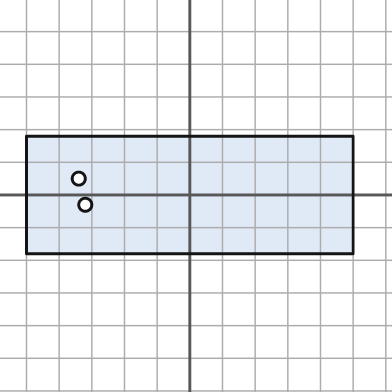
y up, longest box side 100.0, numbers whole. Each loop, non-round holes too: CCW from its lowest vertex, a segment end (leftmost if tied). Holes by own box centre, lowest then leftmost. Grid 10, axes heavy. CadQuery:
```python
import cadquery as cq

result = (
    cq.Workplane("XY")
    .moveTo(-50.0, -18.0)
    .lineTo(50.0, -18.0)
    .lineTo(50.0, 18.0)
    .lineTo(-50.0, 18.0)
    .close()
    .moveTo(-32.0, -3.0)
    .circle(2.0)
    .moveTo(-34.0, 5.0)
    .circle(2.0)
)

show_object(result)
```